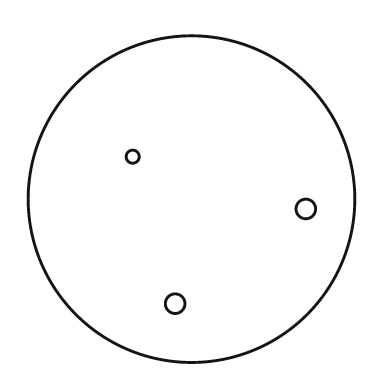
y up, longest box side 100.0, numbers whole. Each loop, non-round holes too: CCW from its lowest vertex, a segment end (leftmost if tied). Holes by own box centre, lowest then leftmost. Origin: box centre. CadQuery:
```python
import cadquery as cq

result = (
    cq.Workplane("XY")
    .moveTo(0.0, 0.0)
    .circle(50.0)
    .moveTo(-5.0, -32.0)
    .circle(3.0)
    .moveTo(35.0, -3.0)
    .circle(3.0)
    .moveTo(-18.0, 13.0)
    .circle(2.0)
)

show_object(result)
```